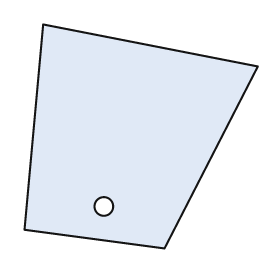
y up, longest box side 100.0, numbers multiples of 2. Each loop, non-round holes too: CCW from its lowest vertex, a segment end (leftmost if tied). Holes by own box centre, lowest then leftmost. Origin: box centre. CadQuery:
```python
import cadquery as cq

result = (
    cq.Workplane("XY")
    .moveTo(10.0, -48.0)
    .lineTo(50.0, 30.0)
    .lineTo(-42.0, 48.0)
    .lineTo(-50.0, -40.0)
    .close()
    .moveTo(-16.0, -30.0)
    .circle(4.0)
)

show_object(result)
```